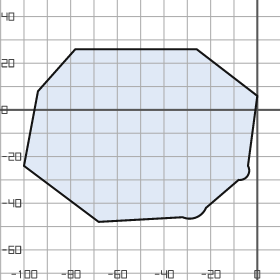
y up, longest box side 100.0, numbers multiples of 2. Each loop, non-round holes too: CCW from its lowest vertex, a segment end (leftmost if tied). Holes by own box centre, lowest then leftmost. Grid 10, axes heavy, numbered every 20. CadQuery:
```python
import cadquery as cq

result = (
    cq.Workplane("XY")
    .moveTo(-68.0, -48.0)
    .lineTo(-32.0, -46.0)
    .threePointArc((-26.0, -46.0), (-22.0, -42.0))
    .lineTo(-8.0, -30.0)
    .threePointArc((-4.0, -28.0), (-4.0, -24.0))
    .lineTo(0.0, 6.0)
    .lineTo(-26.0, 26.0)
    .lineTo(-78.0, 26.0)
    .lineTo(-94.0, 8.0)
    .lineTo(-100.0, -24.0)
    .close()
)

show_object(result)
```